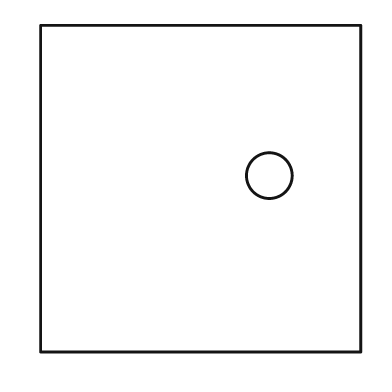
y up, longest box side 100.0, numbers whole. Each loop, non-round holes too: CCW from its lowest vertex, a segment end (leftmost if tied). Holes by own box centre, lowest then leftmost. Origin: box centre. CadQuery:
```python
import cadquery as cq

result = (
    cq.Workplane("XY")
    .moveTo(-49.0, -50.0)
    .lineTo(49.0, -50.0)
    .lineTo(49.0, 50.0)
    .lineTo(-49.0, 50.0)
    .close()
    .moveTo(21.0, 4.0)
    .circle(7.0)
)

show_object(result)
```